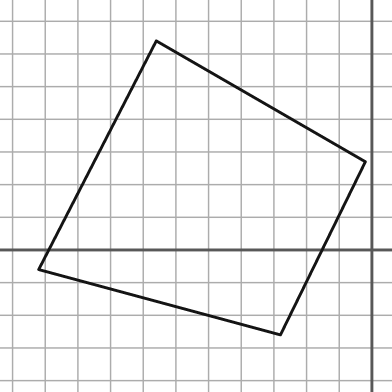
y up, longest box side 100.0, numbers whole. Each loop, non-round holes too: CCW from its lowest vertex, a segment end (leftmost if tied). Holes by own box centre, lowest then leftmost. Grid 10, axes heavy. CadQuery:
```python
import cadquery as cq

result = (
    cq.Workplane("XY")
    .moveTo(-28.0, -26.0)
    .lineTo(-2.0, 27.0)
    .lineTo(-66.0, 64.0)
    .lineTo(-102.0, -6.0)
    .close()
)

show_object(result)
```